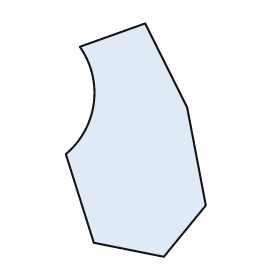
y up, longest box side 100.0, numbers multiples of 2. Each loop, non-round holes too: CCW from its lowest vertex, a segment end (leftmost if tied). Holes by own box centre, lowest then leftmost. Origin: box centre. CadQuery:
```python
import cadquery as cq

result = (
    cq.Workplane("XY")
    .moveTo(12.0, -50.0)
    .lineTo(30.0, -28.0)
    .lineTo(22.0, 14.0)
    .lineTo(4.0, 50.0)
    .lineTo(-24.0, 40.0)
    .threePointArc((-18.0, 16.0), (-30.0, -6.0))
    .lineTo(-18.0, -44.0)
    .close()
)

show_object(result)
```